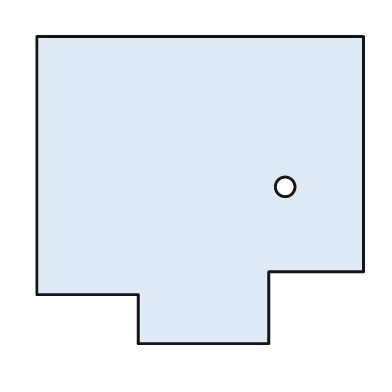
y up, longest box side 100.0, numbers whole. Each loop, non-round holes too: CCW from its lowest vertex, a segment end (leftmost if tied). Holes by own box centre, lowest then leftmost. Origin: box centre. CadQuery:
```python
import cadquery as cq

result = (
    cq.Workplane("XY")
    .moveTo(-19.0, -47.0)
    .lineTo(21.0, -47.0)
    .lineTo(21.0, -25.0)
    .lineTo(50.0, -25.0)
    .lineTo(50.0, 47.0)
    .lineTo(-50.0, 47.0)
    .lineTo(-50.0, -32.0)
    .lineTo(-19.0, -32.0)
    .close()
    .moveTo(26.0, 1.0)
    .circle(3.0)
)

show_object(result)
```